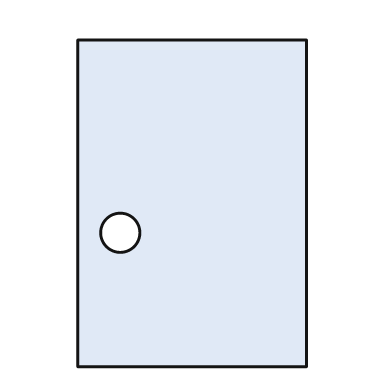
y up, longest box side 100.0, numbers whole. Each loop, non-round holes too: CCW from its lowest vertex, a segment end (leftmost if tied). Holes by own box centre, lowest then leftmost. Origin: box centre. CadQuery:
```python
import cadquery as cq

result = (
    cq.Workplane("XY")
    .moveTo(-35.0, -50.0)
    .lineTo(35.0, -50.0)
    .lineTo(35.0, 50.0)
    .lineTo(-35.0, 50.0)
    .close()
    .moveTo(-22.0, -9.0)
    .circle(6.0)
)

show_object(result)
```